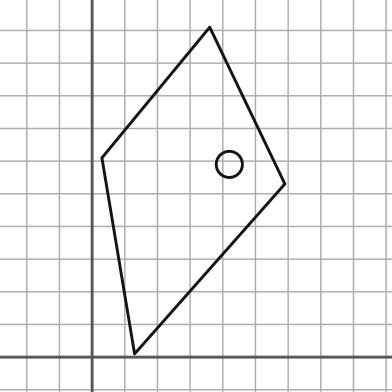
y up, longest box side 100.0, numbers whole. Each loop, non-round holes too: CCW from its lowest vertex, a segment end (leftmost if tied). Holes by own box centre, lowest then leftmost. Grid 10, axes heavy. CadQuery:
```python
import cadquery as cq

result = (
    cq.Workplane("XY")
    .moveTo(13.0, 1.0)
    .lineTo(59.0, 53.0)
    .lineTo(36.0, 101.0)
    .lineTo(3.0, 61.0)
    .close()
    .moveTo(42.0, 59.0)
    .circle(4.0)
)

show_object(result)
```